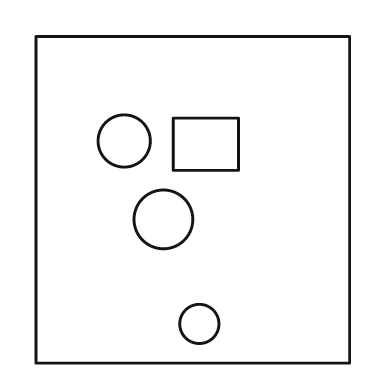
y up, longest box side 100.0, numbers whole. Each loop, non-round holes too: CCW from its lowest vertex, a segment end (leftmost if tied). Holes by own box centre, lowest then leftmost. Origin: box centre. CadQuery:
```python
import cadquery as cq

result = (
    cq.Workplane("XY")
    .moveTo(-48.0, -50.0)
    .lineTo(48.0, -50.0)
    .lineTo(48.0, 50.0)
    .lineTo(-48.0, 50.0)
    .close()
    .moveTo(2.0, -38.0)
    .circle(6.0)
    .moveTo(-9.0, -6.0)
    .circle(9.0)
    .moveTo(-6.0, 9.0)
    .lineTo(14.0, 9.0)
    .lineTo(14.0, 25.0)
    .lineTo(-6.0, 25.0)
    .close()
    .moveTo(-21.0, 18.0)
    .circle(8.0)
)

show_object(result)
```